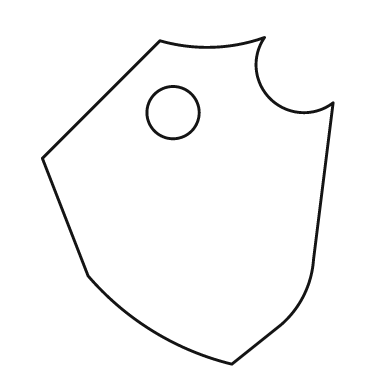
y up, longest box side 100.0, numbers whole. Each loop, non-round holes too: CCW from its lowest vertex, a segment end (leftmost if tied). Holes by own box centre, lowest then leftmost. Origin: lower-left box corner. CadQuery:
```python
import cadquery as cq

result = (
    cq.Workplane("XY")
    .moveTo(58.0, 0.0)
    .lineTo(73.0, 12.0)
    .threePointArc((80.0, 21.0), (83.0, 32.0))
    .lineTo(89.0, 80.0)
    .threePointArc((70.0, 81.0), (68.0, 100.0))
    .threePointArc((52.0, 97.0), (36.0, 99.0))
    .lineTo(0.0, 63.0)
    .lineTo(14.0, 27.0)
    .threePointArc((34.0, 10.0), (58.0, 0.0))
    .close()
    .moveTo(40.0, 77.0)
    .circle(8.0)
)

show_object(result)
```